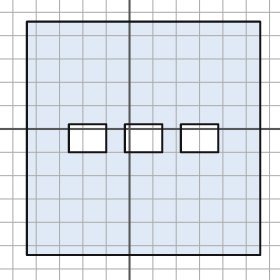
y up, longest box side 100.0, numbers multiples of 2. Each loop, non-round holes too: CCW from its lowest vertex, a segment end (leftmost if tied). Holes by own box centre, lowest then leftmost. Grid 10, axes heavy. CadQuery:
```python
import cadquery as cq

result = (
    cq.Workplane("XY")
    .moveTo(-44.0, -54.0)
    .lineTo(56.0, -54.0)
    .lineTo(56.0, 46.0)
    .lineTo(-44.0, 46.0)
    .close()
    .moveTo(-26.0, -10.0)
    .lineTo(-10.0, -10.0)
    .lineTo(-10.0, 2.0)
    .lineTo(-26.0, 2.0)
    .close()
    .moveTo(-2.0, -10.0)
    .lineTo(14.0, -10.0)
    .lineTo(14.0, 2.0)
    .lineTo(-2.0, 2.0)
    .close()
    .moveTo(22.0, -10.0)
    .lineTo(38.0, -10.0)
    .lineTo(38.0, 2.0)
    .lineTo(22.0, 2.0)
    .close()
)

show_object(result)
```